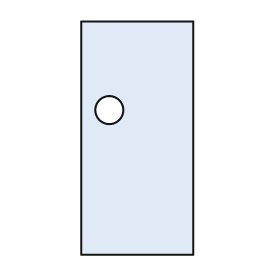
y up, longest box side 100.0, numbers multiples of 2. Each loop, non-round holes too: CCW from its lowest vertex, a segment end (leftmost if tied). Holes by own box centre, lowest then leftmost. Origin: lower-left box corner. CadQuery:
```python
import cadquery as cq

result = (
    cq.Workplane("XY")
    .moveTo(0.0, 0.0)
    .lineTo(48.0, 0.0)
    .lineTo(48.0, 100.0)
    .lineTo(0.0, 100.0)
    .close()
    .moveTo(12.0, 62.0)
    .circle(6.0)
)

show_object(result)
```